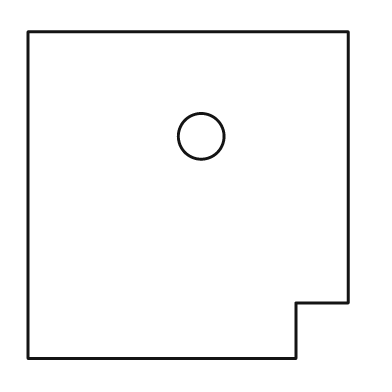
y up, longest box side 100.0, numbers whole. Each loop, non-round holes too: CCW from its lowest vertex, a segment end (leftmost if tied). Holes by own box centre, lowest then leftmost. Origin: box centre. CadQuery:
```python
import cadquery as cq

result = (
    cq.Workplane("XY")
    .moveTo(-49.0, -50.0)
    .lineTo(33.0, -50.0)
    .lineTo(33.0, -33.0)
    .lineTo(49.0, -33.0)
    .lineTo(49.0, 50.0)
    .lineTo(-49.0, 50.0)
    .close()
    .moveTo(4.0, 18.0)
    .circle(7.0)
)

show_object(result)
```